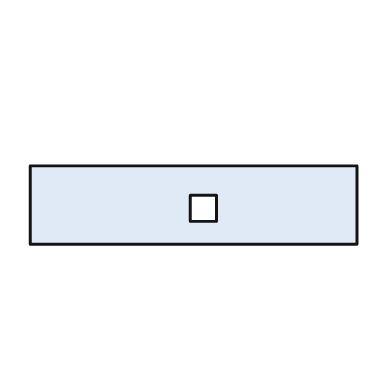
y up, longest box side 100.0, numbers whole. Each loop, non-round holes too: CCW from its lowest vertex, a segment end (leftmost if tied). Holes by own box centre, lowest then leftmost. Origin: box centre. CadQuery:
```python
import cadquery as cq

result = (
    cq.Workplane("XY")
    .moveTo(-50.0, -12.0)
    .lineTo(50.0, -12.0)
    .lineTo(50.0, 12.0)
    .lineTo(-50.0, 12.0)
    .close()
    .moveTo(-1.0, -5.0)
    .lineTo(7.0, -5.0)
    .lineTo(7.0, 3.0)
    .lineTo(-1.0, 3.0)
    .close()
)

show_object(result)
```